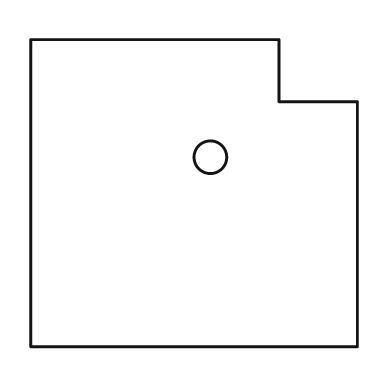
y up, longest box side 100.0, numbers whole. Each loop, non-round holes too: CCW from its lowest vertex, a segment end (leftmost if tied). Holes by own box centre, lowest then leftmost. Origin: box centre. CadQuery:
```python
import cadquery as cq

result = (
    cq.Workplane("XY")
    .moveTo(-50.0, -47.0)
    .lineTo(50.0, -47.0)
    .lineTo(50.0, 28.0)
    .lineTo(26.0, 28.0)
    .lineTo(26.0, 47.0)
    .lineTo(-50.0, 47.0)
    .close()
    .moveTo(5.0, 11.0)
    .circle(5.0)
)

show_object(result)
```